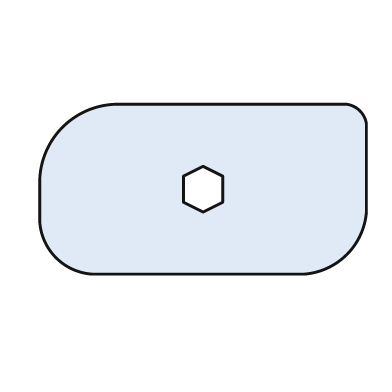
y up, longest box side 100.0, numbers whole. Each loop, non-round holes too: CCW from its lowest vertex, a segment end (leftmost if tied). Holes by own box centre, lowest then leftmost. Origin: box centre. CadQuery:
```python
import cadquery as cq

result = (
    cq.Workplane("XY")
    .moveTo(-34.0, -26.0)
    .lineTo(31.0, -26.0)
    .threePointArc((44.0, -20.0), (50.0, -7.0))
    .lineTo(50.0, 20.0)
    .threePointArc((48.0, 24.0), (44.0, 26.0))
    .lineTo(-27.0, 26.0)
    .threePointArc((-43.0, 19.0), (-50.0, 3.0))
    .lineTo(-50.0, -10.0)
    .threePointArc((-45.0, -21.0), (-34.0, -26.0))
    .close()
    .moveTo(0.0, -7.0)
    .lineTo(6.0, -4.0)
    .lineTo(6.0, 4.0)
    .lineTo(0.0, 7.0)
    .lineTo(-6.0, 4.0)
    .lineTo(-6.0, -4.0)
    .close()
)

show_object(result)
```